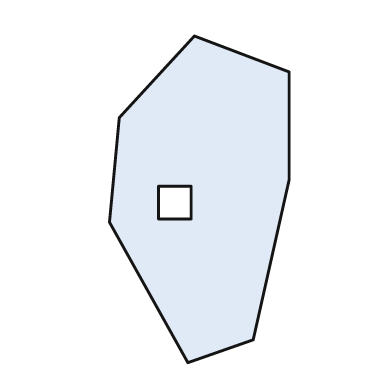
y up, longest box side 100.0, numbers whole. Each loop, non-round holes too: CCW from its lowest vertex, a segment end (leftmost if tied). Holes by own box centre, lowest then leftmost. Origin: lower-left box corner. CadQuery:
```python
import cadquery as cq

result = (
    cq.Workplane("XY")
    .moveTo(24.0, 0.0)
    .lineTo(44.0, 7.0)
    .lineTo(55.0, 56.0)
    .lineTo(55.0, 89.0)
    .lineTo(26.0, 100.0)
    .lineTo(3.0, 75.0)
    .lineTo(0.0, 43.0)
    .close()
    .moveTo(15.0, 44.0)
    .lineTo(25.0, 44.0)
    .lineTo(25.0, 54.0)
    .lineTo(15.0, 54.0)
    .close()
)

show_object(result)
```